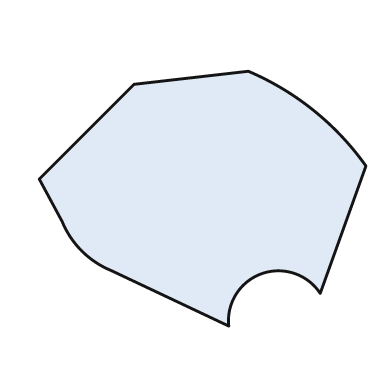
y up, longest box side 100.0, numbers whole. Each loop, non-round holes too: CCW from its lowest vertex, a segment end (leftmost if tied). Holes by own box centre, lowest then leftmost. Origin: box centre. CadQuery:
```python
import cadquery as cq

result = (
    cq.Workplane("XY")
    .moveTo(8.0, -39.0)
    .threePointArc((18.0, -23.0), (36.0, -29.0))
    .lineTo(50.0, 10.0)
    .threePointArc((34.0, 27.0), (14.0, 39.0))
    .lineTo(-21.0, 35.0)
    .lineTo(-50.0, 6.0)
    .lineTo(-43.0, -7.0)
    .threePointArc((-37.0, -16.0), (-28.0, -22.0))
    .close()
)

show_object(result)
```